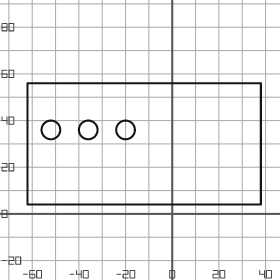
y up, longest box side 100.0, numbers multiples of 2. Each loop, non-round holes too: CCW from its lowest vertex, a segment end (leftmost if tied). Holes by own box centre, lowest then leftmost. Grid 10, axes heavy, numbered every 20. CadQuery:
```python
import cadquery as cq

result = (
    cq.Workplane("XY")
    .moveTo(-62.0, 4.0)
    .lineTo(38.0, 4.0)
    .lineTo(38.0, 56.0)
    .lineTo(-62.0, 56.0)
    .close()
    .moveTo(-52.0, 36.0)
    .circle(4.0)
    .moveTo(-36.0, 36.0)
    .circle(4.0)
    .moveTo(-20.0, 36.0)
    .circle(4.0)
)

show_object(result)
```